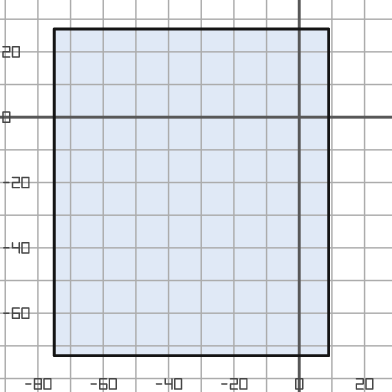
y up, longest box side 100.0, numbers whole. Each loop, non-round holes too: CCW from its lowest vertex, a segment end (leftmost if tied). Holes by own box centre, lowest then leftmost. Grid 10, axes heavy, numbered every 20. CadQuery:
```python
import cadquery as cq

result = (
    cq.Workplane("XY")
    .moveTo(-75.0, -73.0)
    .lineTo(9.0, -73.0)
    .lineTo(9.0, 27.0)
    .lineTo(-75.0, 27.0)
    .close()
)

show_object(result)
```